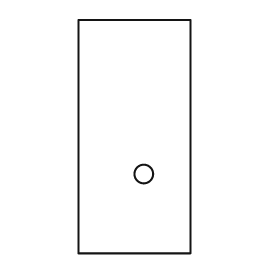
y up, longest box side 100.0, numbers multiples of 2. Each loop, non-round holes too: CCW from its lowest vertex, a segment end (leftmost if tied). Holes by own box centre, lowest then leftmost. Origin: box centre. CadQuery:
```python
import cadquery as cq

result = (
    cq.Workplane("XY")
    .moveTo(-24.0, -50.0)
    .lineTo(24.0, -50.0)
    .lineTo(24.0, 50.0)
    .lineTo(-24.0, 50.0)
    .close()
    .moveTo(4.0, -16.0)
    .circle(4.0)
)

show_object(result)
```